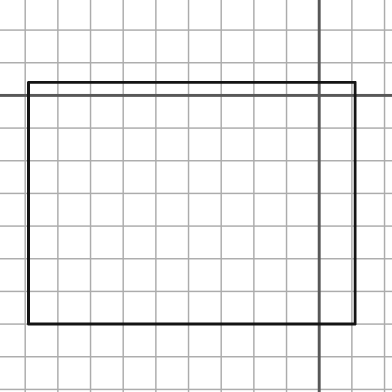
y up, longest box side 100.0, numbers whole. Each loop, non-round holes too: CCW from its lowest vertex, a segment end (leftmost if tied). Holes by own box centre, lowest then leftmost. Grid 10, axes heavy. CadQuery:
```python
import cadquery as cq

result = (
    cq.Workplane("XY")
    .moveTo(-89.0, -70.0)
    .lineTo(11.0, -70.0)
    .lineTo(11.0, 4.0)
    .lineTo(-89.0, 4.0)
    .close()
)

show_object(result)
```